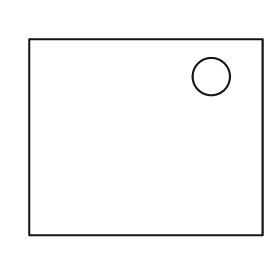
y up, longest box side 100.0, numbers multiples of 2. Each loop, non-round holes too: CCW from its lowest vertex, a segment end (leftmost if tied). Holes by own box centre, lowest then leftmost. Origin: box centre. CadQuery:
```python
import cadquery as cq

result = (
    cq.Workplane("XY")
    .moveTo(-50.0, -42.0)
    .lineTo(50.0, -42.0)
    .lineTo(50.0, 42.0)
    .lineTo(-50.0, 42.0)
    .close()
    .moveTo(28.0, 26.0)
    .circle(8.0)
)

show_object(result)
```